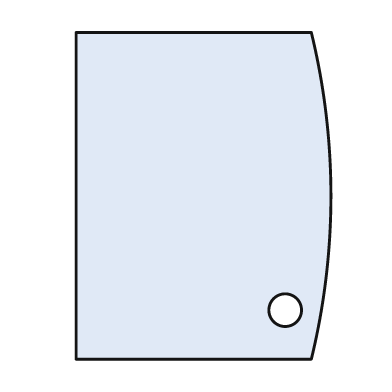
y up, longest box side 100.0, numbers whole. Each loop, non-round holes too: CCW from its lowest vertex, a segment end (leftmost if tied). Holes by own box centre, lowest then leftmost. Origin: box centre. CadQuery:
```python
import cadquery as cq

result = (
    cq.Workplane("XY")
    .moveTo(-39.0, -50.0)
    .lineTo(33.0, -50.0)
    .threePointArc((39.0, 0.0), (33.0, 50.0))
    .lineTo(-39.0, 50.0)
    .close()
    .moveTo(25.0, -35.0)
    .circle(5.0)
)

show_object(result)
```